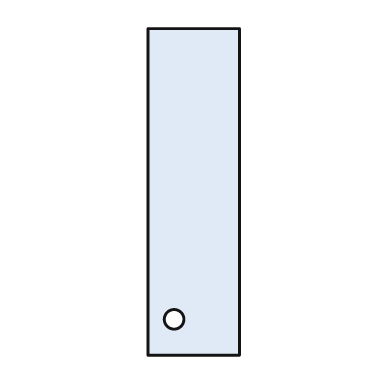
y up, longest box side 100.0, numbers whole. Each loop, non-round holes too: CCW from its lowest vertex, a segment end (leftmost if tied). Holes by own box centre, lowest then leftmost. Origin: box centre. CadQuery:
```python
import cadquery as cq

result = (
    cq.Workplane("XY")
    .moveTo(-14.0, -50.0)
    .lineTo(14.0, -50.0)
    .lineTo(14.0, 50.0)
    .lineTo(-14.0, 50.0)
    .close()
    .moveTo(-6.0, -39.0)
    .circle(3.0)
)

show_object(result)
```